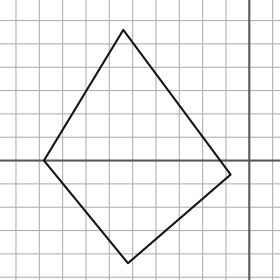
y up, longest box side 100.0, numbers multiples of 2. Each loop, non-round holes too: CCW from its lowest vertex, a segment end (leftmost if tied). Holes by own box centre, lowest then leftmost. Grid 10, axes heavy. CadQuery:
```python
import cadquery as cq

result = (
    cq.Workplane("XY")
    .moveTo(-52.0, -44.0)
    .lineTo(-8.0, -6.0)
    .lineTo(-54.0, 56.0)
    .lineTo(-88.0, 0.0)
    .close()
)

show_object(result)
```